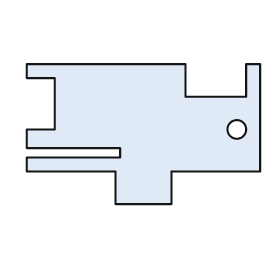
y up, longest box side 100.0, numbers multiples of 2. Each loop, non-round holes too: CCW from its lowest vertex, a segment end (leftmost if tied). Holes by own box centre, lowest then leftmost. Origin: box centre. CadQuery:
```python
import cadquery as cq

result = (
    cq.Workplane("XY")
    .moveTo(-12.0, -30.0)
    .lineTo(12.0, -30.0)
    .lineTo(12.0, -16.0)
    .lineTo(50.0, -16.0)
    .lineTo(50.0, 30.0)
    .lineTo(44.0, 30.0)
    .lineTo(44.0, 16.0)
    .lineTo(18.0, 16.0)
    .lineTo(18.0, 30.0)
    .lineTo(-50.0, 30.0)
    .lineTo(-50.0, 24.0)
    .lineTo(-38.0, 24.0)
    .lineTo(-38.0, 2.0)
    .lineTo(-50.0, 2.0)
    .lineTo(-50.0, -6.0)
    .lineTo(-10.0, -6.0)
    .lineTo(-10.0, -10.0)
    .lineTo(-50.0, -10.0)
    .lineTo(-50.0, -16.0)
    .lineTo(-12.0, -16.0)
    .close()
    .moveTo(40.0, 2.0)
    .circle(4.0)
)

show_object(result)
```